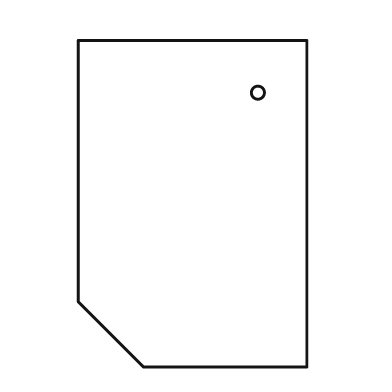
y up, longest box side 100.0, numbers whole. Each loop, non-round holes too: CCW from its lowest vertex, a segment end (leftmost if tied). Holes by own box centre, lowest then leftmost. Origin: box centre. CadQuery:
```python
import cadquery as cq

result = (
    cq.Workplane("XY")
    .moveTo(-15.0, -50.0)
    .lineTo(35.0, -50.0)
    .lineTo(35.0, 50.0)
    .lineTo(-35.0, 50.0)
    .lineTo(-35.0, -30.0)
    .close()
    .moveTo(20.0, 34.0)
    .circle(2.0)
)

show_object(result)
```